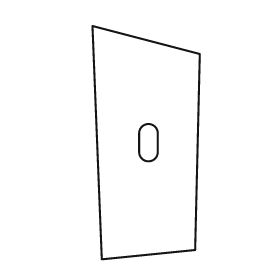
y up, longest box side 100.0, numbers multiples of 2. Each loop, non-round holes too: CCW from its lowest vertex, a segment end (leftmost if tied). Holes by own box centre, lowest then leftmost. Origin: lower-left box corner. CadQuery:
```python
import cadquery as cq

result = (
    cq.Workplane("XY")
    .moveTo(4.0, 0.0)
    .lineTo(44.0, 4.0)
    .lineTo(46.0, 88.0)
    .lineTo(0.0, 100.0)
    .close()
    .moveTo(20.0, 46.0)
    .threePointArc((24.0, 42.0), (28.0, 46.0))
    .lineTo(28.0, 54.0)
    .threePointArc((24.0, 58.0), (20.0, 54.0))
    .close()
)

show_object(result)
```